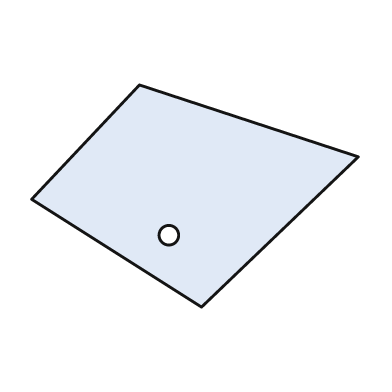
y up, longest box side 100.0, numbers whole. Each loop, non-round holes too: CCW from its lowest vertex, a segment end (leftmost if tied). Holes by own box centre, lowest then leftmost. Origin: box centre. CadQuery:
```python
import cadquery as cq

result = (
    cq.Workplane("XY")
    .moveTo(2.0, -34.0)
    .lineTo(50.0, 12.0)
    .lineTo(-17.0, 34.0)
    .lineTo(-50.0, -1.0)
    .close()
    .moveTo(-8.0, -12.0)
    .circle(3.0)
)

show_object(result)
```